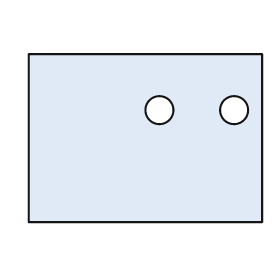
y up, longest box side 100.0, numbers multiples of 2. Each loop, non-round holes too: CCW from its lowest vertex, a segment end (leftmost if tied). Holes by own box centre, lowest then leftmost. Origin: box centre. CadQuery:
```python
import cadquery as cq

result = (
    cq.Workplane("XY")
    .moveTo(-50.0, -36.0)
    .lineTo(50.0, -36.0)
    .lineTo(50.0, 36.0)
    .lineTo(-50.0, 36.0)
    .close()
    .moveTo(6.0, 12.0)
    .circle(6.0)
    .moveTo(38.0, 12.0)
    .circle(6.0)
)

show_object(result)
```